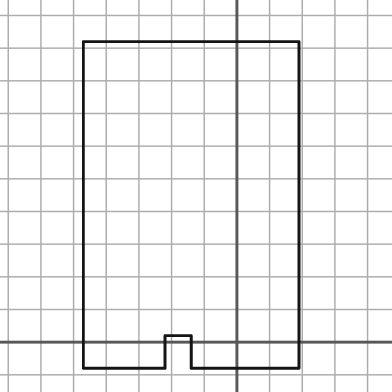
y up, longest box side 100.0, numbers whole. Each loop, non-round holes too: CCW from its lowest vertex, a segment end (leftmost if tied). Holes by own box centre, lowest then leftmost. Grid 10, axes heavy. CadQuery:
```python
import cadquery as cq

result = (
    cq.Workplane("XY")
    .moveTo(-47.0, -8.0)
    .lineTo(-22.0, -8.0)
    .lineTo(-22.0, 2.0)
    .lineTo(-14.0, 2.0)
    .lineTo(-14.0, -8.0)
    .lineTo(19.0, -8.0)
    .lineTo(19.0, 92.0)
    .lineTo(-47.0, 92.0)
    .close()
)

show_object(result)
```